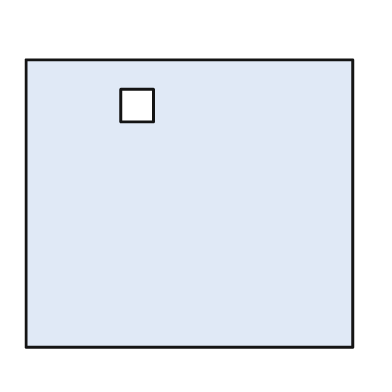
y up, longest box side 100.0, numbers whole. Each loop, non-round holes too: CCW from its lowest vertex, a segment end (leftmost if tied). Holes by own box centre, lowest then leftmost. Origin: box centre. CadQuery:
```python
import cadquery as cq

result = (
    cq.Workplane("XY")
    .moveTo(-50.0, -44.0)
    .lineTo(50.0, -44.0)
    .lineTo(50.0, 44.0)
    .lineTo(-50.0, 44.0)
    .close()
    .moveTo(-21.0, 25.0)
    .lineTo(-11.0, 25.0)
    .lineTo(-11.0, 35.0)
    .lineTo(-21.0, 35.0)
    .close()
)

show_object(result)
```